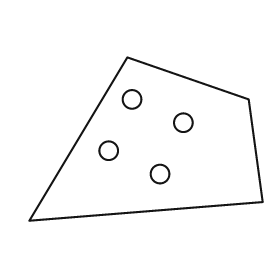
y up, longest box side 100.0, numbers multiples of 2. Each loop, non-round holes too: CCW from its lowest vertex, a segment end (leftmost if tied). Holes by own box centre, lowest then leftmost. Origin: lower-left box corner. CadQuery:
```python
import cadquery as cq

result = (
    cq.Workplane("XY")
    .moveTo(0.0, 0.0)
    .lineTo(100.0, 8.0)
    .lineTo(94.0, 52.0)
    .lineTo(42.0, 70.0)
    .close()
    .moveTo(56.0, 20.0)
    .circle(4.0)
    .moveTo(34.0, 30.0)
    .circle(4.0)
    .moveTo(66.0, 42.0)
    .circle(4.0)
    .moveTo(44.0, 52.0)
    .circle(4.0)
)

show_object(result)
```